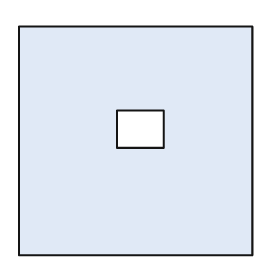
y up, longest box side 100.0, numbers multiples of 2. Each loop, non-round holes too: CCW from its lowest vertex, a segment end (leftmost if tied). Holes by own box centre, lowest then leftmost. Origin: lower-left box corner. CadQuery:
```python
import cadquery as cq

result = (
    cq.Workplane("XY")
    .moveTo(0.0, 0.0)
    .lineTo(100.0, 0.0)
    .lineTo(100.0, 98.0)
    .lineTo(0.0, 98.0)
    .close()
    .moveTo(42.0, 46.0)
    .lineTo(62.0, 46.0)
    .lineTo(62.0, 62.0)
    .lineTo(42.0, 62.0)
    .close()
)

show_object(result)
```